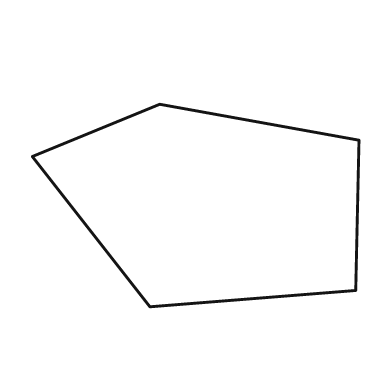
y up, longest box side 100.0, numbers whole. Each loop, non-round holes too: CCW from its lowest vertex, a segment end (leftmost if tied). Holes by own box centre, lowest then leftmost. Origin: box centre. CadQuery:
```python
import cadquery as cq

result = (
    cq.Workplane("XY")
    .moveTo(-14.0, -31.0)
    .lineTo(49.0, -26.0)
    .lineTo(50.0, 20.0)
    .lineTo(-11.0, 31.0)
    .lineTo(-50.0, 15.0)
    .close()
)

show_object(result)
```